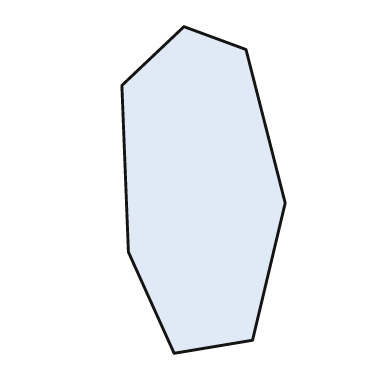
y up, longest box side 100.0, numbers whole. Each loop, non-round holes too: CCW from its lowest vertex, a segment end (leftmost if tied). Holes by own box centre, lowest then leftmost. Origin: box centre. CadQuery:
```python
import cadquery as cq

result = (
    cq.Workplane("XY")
    .moveTo(-9.0, -50.0)
    .lineTo(15.0, -46.0)
    .lineTo(25.0, -4.0)
    .lineTo(13.0, 43.0)
    .lineTo(-6.0, 50.0)
    .lineTo(-25.0, 32.0)
    .lineTo(-23.0, -19.0)
    .close()
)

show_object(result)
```